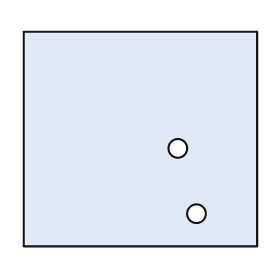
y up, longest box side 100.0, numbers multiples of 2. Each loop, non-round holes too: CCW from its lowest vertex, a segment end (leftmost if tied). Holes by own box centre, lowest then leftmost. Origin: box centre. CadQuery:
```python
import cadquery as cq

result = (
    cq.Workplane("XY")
    .moveTo(-50.0, -46.0)
    .lineTo(50.0, -46.0)
    .lineTo(50.0, 46.0)
    .lineTo(-50.0, 46.0)
    .close()
    .moveTo(24.0, -32.0)
    .circle(4.0)
    .moveTo(16.0, -4.0)
    .circle(4.0)
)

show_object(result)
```